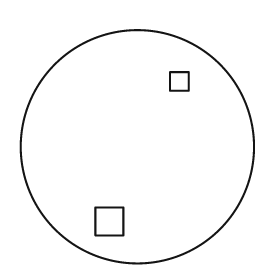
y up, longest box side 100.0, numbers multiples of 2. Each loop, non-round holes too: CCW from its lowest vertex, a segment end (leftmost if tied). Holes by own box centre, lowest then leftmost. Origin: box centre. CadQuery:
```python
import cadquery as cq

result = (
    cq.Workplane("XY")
    .moveTo(0.0, 0.0)
    .circle(50.0)
    .moveTo(-18.0, -38.0)
    .lineTo(-6.0, -38.0)
    .lineTo(-6.0, -26.0)
    .lineTo(-18.0, -26.0)
    .close()
    .moveTo(14.0, 24.0)
    .lineTo(22.0, 24.0)
    .lineTo(22.0, 32.0)
    .lineTo(14.0, 32.0)
    .close()
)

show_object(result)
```